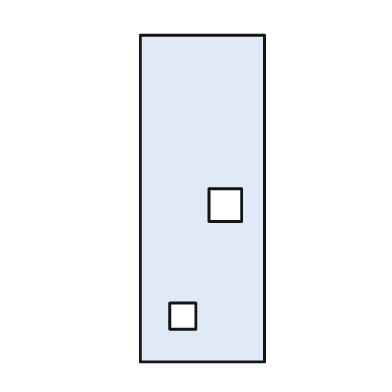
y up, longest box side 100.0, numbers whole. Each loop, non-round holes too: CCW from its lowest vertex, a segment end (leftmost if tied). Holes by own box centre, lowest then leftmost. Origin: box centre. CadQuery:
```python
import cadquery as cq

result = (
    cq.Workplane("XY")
    .moveTo(-19.0, -50.0)
    .lineTo(19.0, -50.0)
    .lineTo(19.0, 50.0)
    .lineTo(-19.0, 50.0)
    .close()
    .moveTo(-10.0, -40.0)
    .lineTo(-2.0, -40.0)
    .lineTo(-2.0, -32.0)
    .lineTo(-10.0, -32.0)
    .close()
    .moveTo(2.0, -7.0)
    .lineTo(12.0, -7.0)
    .lineTo(12.0, 3.0)
    .lineTo(2.0, 3.0)
    .close()
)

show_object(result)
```